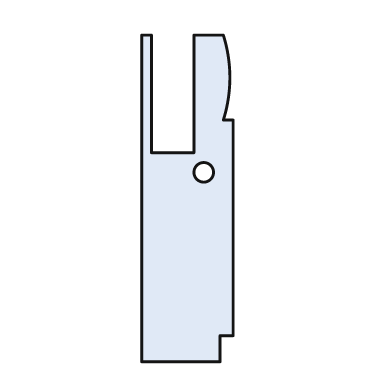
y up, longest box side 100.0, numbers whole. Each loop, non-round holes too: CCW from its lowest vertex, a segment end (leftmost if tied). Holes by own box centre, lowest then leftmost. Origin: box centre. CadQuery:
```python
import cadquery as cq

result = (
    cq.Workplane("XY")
    .moveTo(-14.0, -50.0)
    .lineTo(10.0, -50.0)
    .lineTo(10.0, -42.0)
    .lineTo(14.0, -42.0)
    .lineTo(14.0, 24.0)
    .lineTo(11.0, 24.0)
    .threePointArc((13.0, 37.0), (11.0, 50.0))
    .lineTo(2.0, 50.0)
    .lineTo(2.0, 14.0)
    .lineTo(-11.0, 14.0)
    .lineTo(-11.0, 50.0)
    .lineTo(-14.0, 50.0)
    .close()
    .moveTo(5.0, 8.0)
    .circle(3.0)
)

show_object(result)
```